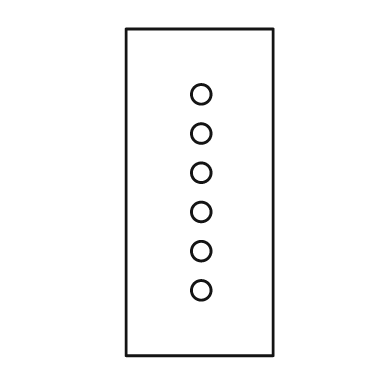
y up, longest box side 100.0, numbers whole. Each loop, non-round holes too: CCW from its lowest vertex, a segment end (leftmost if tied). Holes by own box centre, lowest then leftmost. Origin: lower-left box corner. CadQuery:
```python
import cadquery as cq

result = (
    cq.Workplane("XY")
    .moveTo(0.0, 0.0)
    .lineTo(45.0, 0.0)
    .lineTo(45.0, 100.0)
    .lineTo(0.0, 100.0)
    .close()
    .moveTo(23.0, 20.0)
    .circle(3.0)
    .moveTo(23.0, 32.0)
    .circle(3.0)
    .moveTo(23.0, 44.0)
    .circle(3.0)
    .moveTo(23.0, 56.0)
    .circle(3.0)
    .moveTo(23.0, 68.0)
    .circle(3.0)
    .moveTo(23.0, 80.0)
    .circle(3.0)
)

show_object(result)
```